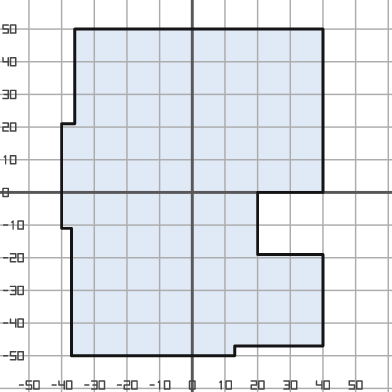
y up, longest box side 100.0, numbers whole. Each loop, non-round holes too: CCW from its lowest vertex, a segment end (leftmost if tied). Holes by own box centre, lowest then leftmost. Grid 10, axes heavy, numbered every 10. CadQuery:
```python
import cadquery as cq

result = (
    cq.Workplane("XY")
    .moveTo(-37.0, -50.0)
    .lineTo(13.0, -50.0)
    .lineTo(13.0, -47.0)
    .lineTo(40.0, -47.0)
    .lineTo(40.0, -19.0)
    .lineTo(20.0, -19.0)
    .lineTo(20.0, 0.0)
    .lineTo(40.0, 0.0)
    .lineTo(40.0, 50.0)
    .lineTo(-36.0, 50.0)
    .lineTo(-36.0, 21.0)
    .lineTo(-40.0, 21.0)
    .lineTo(-40.0, -11.0)
    .lineTo(-37.0, -11.0)
    .close()
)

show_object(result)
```